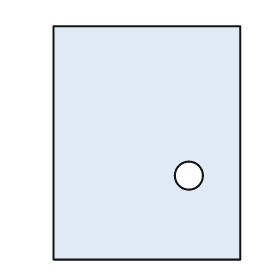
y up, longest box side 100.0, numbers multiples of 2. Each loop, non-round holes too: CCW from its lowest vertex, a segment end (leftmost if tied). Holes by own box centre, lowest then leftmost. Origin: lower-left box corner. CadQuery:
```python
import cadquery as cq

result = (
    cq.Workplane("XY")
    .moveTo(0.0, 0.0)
    .lineTo(80.0, 0.0)
    .lineTo(80.0, 100.0)
    .lineTo(0.0, 100.0)
    .close()
    .moveTo(58.0, 36.0)
    .circle(6.0)
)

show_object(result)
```